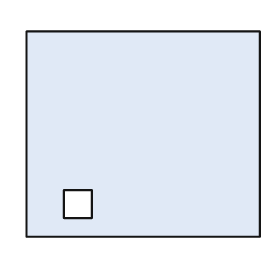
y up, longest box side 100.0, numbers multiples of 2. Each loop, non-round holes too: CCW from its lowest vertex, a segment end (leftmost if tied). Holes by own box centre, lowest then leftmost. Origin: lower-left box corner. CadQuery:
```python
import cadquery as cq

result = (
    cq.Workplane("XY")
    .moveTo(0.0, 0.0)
    .lineTo(100.0, 0.0)
    .lineTo(100.0, 88.0)
    .lineTo(0.0, 88.0)
    .close()
    .moveTo(16.0, 8.0)
    .lineTo(28.0, 8.0)
    .lineTo(28.0, 20.0)
    .lineTo(16.0, 20.0)
    .close()
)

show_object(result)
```